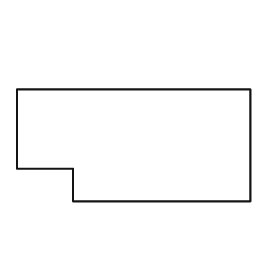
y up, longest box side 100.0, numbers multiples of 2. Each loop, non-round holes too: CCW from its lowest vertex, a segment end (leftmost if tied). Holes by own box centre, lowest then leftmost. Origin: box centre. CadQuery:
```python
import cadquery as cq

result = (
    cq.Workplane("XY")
    .moveTo(-26.0, -24.0)
    .lineTo(50.0, -24.0)
    .lineTo(50.0, 24.0)
    .lineTo(-50.0, 24.0)
    .lineTo(-50.0, -10.0)
    .lineTo(-26.0, -10.0)
    .close()
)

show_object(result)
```